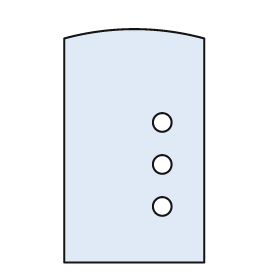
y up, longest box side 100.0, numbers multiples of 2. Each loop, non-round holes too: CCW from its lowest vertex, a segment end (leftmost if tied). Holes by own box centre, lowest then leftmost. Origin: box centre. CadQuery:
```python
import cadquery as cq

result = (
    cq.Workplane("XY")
    .moveTo(-30.0, -50.0)
    .lineTo(30.0, -50.0)
    .lineTo(30.0, 46.0)
    .threePointArc((0.0, 50.0), (-30.0, 46.0))
    .close()
    .moveTo(12.0, -26.0)
    .circle(4.0)
    .moveTo(12.0, -8.0)
    .circle(4.0)
    .moveTo(12.0, 10.0)
    .circle(4.0)
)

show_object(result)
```